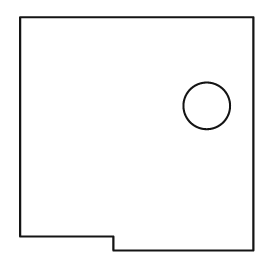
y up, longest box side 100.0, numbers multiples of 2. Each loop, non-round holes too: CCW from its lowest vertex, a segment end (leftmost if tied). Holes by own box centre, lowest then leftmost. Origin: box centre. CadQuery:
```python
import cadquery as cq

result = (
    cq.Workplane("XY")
    .moveTo(-10.0, -50.0)
    .lineTo(50.0, -50.0)
    .lineTo(50.0, 50.0)
    .lineTo(-50.0, 50.0)
    .lineTo(-50.0, -44.0)
    .lineTo(-10.0, -44.0)
    .close()
    .moveTo(30.0, 12.0)
    .circle(10.0)
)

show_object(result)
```